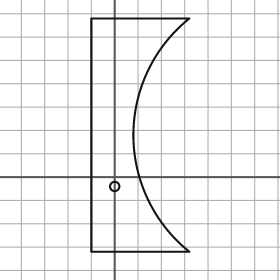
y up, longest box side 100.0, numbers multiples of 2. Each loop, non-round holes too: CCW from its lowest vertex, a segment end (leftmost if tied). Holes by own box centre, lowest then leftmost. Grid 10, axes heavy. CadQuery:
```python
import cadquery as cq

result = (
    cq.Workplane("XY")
    .moveTo(-10.0, -32.0)
    .lineTo(32.0, -32.0)
    .threePointArc((8.0, 18.0), (32.0, 68.0))
    .lineTo(-10.0, 68.0)
    .close()
    .moveTo(0.0, -4.0)
    .circle(2.0)
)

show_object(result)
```